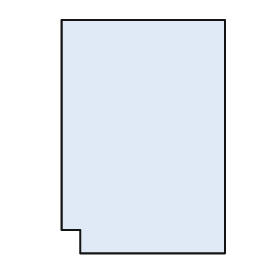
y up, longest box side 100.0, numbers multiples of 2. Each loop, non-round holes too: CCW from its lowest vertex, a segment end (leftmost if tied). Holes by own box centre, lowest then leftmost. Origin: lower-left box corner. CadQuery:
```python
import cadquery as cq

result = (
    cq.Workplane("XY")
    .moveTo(8.0, 0.0)
    .lineTo(70.0, 0.0)
    .lineTo(70.0, 100.0)
    .lineTo(0.0, 100.0)
    .lineTo(0.0, 10.0)
    .lineTo(8.0, 10.0)
    .close()
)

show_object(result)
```